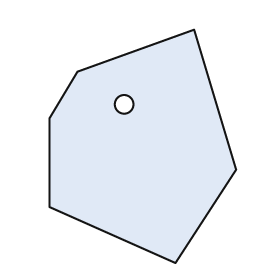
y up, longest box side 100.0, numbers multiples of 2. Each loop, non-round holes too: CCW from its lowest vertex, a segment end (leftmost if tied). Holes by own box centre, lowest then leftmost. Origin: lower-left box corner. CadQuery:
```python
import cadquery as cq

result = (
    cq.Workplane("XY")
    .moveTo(54.0, 0.0)
    .lineTo(80.0, 40.0)
    .lineTo(62.0, 100.0)
    .lineTo(12.0, 82.0)
    .lineTo(0.0, 62.0)
    .lineTo(0.0, 24.0)
    .close()
    .moveTo(32.0, 68.0)
    .circle(4.0)
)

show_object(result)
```